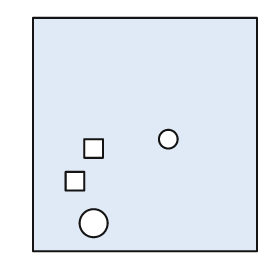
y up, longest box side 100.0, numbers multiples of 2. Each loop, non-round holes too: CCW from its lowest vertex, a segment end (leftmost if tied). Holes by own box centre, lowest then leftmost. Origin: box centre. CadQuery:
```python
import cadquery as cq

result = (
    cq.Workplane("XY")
    .moveTo(-48.0, -50.0)
    .lineTo(48.0, -50.0)
    .lineTo(48.0, 50.0)
    .lineTo(-48.0, 50.0)
    .close()
    .moveTo(-22.0, -38.0)
    .circle(6.0)
    .moveTo(-34.0, -24.0)
    .lineTo(-26.0, -24.0)
    .lineTo(-26.0, -16.0)
    .lineTo(-34.0, -16.0)
    .close()
    .moveTo(-26.0, -10.0)
    .lineTo(-18.0, -10.0)
    .lineTo(-18.0, -2.0)
    .lineTo(-26.0, -2.0)
    .close()
    .moveTo(10.0, -2.0)
    .circle(4.0)
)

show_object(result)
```